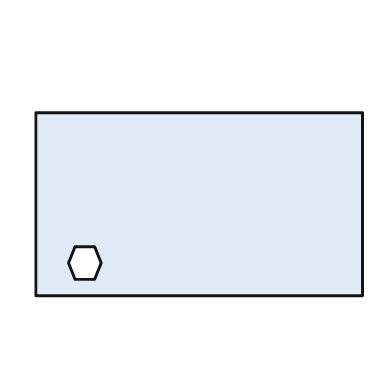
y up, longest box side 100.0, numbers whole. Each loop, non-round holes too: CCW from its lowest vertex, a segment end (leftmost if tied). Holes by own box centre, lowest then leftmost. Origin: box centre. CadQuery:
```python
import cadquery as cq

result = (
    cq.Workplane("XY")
    .moveTo(-50.0, -28.0)
    .lineTo(50.0, -28.0)
    .lineTo(50.0, 28.0)
    .lineTo(-50.0, 28.0)
    .close()
    .moveTo(-38.0, -23.0)
    .lineTo(-32.0, -23.0)
    .lineTo(-30.0, -18.0)
    .lineTo(-32.0, -13.0)
    .lineTo(-38.0, -13.0)
    .lineTo(-40.0, -18.0)
    .close()
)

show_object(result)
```